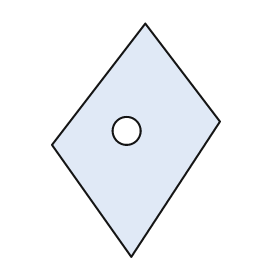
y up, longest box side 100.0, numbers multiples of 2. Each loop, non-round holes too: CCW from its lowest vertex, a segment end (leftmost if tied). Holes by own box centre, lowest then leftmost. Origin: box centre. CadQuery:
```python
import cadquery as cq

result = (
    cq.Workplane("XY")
    .moveTo(-2.0, -50.0)
    .lineTo(36.0, 8.0)
    .lineTo(4.0, 50.0)
    .lineTo(-36.0, -2.0)
    .close()
    .moveTo(-4.0, 4.0)
    .circle(6.0)
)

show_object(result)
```